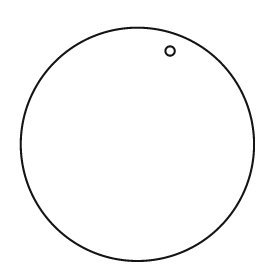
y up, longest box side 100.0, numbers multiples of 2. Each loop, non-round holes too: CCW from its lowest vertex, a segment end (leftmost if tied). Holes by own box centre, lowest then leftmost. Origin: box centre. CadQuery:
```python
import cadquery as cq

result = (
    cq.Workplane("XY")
    .moveTo(0.0, 0.0)
    .circle(50.0)
    .moveTo(14.0, 40.0)
    .circle(2.0)
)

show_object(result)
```